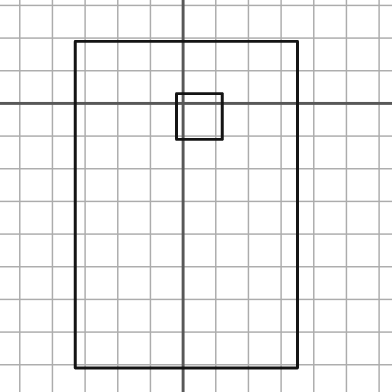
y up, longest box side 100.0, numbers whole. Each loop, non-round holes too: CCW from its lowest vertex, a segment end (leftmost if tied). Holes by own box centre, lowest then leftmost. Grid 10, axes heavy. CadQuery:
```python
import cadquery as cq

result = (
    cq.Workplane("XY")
    .moveTo(-33.0, -81.0)
    .lineTo(35.0, -81.0)
    .lineTo(35.0, 19.0)
    .lineTo(-33.0, 19.0)
    .close()
    .moveTo(-2.0, -11.0)
    .lineTo(12.0, -11.0)
    .lineTo(12.0, 3.0)
    .lineTo(-2.0, 3.0)
    .close()
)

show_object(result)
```